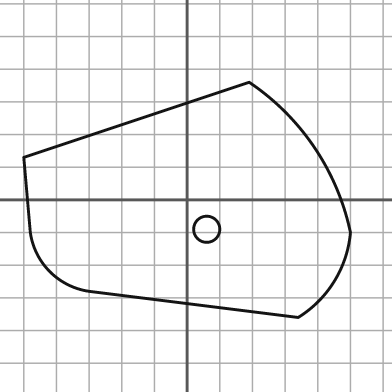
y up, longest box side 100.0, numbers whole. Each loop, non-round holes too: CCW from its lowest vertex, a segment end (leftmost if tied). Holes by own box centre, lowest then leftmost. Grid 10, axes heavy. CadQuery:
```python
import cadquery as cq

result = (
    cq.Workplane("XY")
    .moveTo(34.0, -36.0)
    .threePointArc((45.0, -25.0), (50.0, -10.0))
    .threePointArc((39.0, 16.0), (19.0, 36.0))
    .lineTo(-50.0, 13.0)
    .lineTo(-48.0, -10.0)
    .threePointArc((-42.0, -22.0), (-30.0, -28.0))
    .close()
    .moveTo(6.0, -9.0)
    .circle(4.0)
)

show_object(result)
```